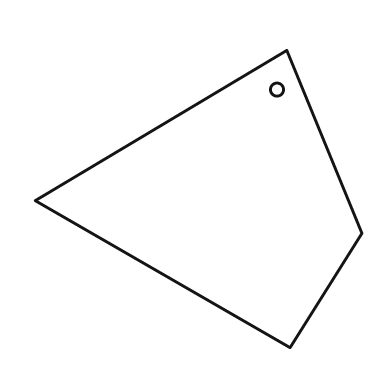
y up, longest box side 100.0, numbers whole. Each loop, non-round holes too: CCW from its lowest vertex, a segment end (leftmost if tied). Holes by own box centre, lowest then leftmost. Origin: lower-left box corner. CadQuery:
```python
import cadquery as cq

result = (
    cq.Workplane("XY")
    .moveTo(78.0, 0.0)
    .lineTo(100.0, 35.0)
    .lineTo(77.0, 91.0)
    .lineTo(0.0, 45.0)
    .close()
    .moveTo(74.0, 79.0)
    .circle(2.0)
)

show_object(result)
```